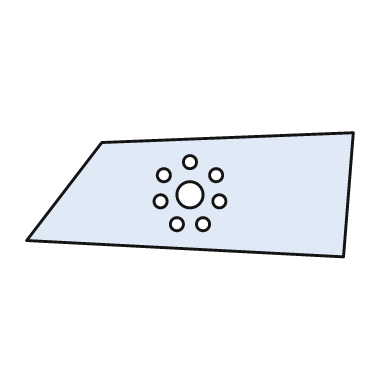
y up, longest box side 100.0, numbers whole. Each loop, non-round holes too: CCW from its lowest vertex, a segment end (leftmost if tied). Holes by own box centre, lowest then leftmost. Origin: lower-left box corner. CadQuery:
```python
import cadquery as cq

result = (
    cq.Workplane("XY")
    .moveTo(97.0, 0.0)
    .lineTo(100.0, 38.0)
    .lineTo(23.0, 35.0)
    .lineTo(0.0, 5.0)
    .close()
    .moveTo(46.0, 10.0)
    .circle(2.0)
    .moveTo(54.0, 10.0)
    .circle(2.0)
    .moveTo(41.0, 17.0)
    .circle(2.0)
    .moveTo(59.0, 17.0)
    .circle(2.0)
    .moveTo(50.0, 19.0)
    .circle(4.0)
    .moveTo(42.0, 25.0)
    .circle(2.0)
    .moveTo(58.0, 25.0)
    .circle(2.0)
    .moveTo(50.0, 29.0)
    .circle(2.0)
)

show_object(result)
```